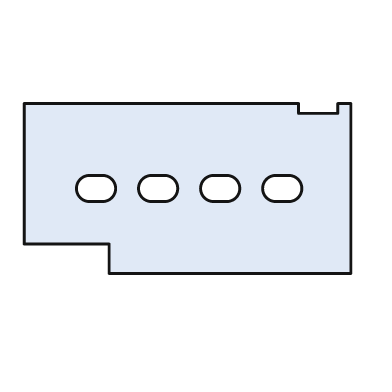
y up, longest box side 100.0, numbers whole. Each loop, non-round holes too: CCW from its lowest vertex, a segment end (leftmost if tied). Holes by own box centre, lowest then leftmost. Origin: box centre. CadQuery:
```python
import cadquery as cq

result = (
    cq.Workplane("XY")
    .moveTo(-24.0, -26.0)
    .lineTo(50.0, -26.0)
    .lineTo(50.0, 26.0)
    .lineTo(46.0, 26.0)
    .lineTo(46.0, 23.0)
    .lineTo(34.0, 23.0)
    .lineTo(34.0, 26.0)
    .lineTo(-50.0, 26.0)
    .lineTo(-50.0, -17.0)
    .lineTo(-24.0, -17.0)
    .close()
    .moveTo(-30.0, -4.0)
    .lineTo(-26.0, -4.0)
    .threePointArc((-22.0, 0.0), (-26.0, 4.0))
    .lineTo(-30.0, 4.0)
    .threePointArc((-34.0, 0.0), (-30.0, -4.0))
    .close()
    .moveTo(-11.0, -4.0)
    .lineTo(-7.0, -4.0)
    .threePointArc((-3.0, 0.0), (-7.0, 4.0))
    .lineTo(-11.0, 4.0)
    .threePointArc((-15.0, 0.0), (-11.0, -4.0))
    .close()
    .moveTo(8.0, -4.0)
    .lineTo(12.0, -4.0)
    .threePointArc((16.0, 0.0), (12.0, 4.0))
    .lineTo(8.0, 4.0)
    .threePointArc((4.0, 0.0), (8.0, -4.0))
    .close()
    .moveTo(27.0, -4.0)
    .lineTo(31.0, -4.0)
    .threePointArc((35.0, 0.0), (31.0, 4.0))
    .lineTo(27.0, 4.0)
    .threePointArc((23.0, 0.0), (27.0, -4.0))
    .close()
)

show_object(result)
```